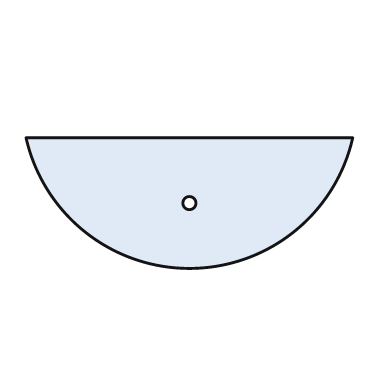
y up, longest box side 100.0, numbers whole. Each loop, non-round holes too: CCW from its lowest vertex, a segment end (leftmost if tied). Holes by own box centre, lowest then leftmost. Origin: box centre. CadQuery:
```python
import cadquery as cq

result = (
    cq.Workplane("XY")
    .moveTo(-50.0, 20.0)
    .threePointArc((0.0, -20.0), (50.0, 20.0))
    .close()
    .moveTo(0.0, 0.0)
    .circle(2.0)
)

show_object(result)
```